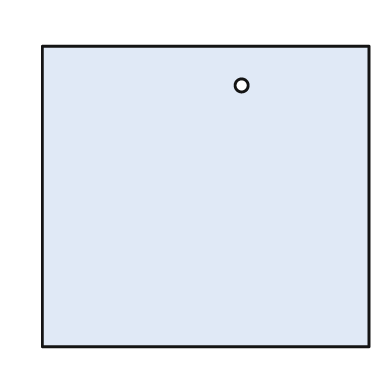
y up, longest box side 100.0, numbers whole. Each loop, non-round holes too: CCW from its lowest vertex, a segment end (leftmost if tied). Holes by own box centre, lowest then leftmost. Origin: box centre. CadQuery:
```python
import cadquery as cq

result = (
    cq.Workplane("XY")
    .moveTo(-50.0, -46.0)
    .lineTo(50.0, -46.0)
    .lineTo(50.0, 46.0)
    .lineTo(-50.0, 46.0)
    .close()
    .moveTo(11.0, 34.0)
    .circle(2.0)
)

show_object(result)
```